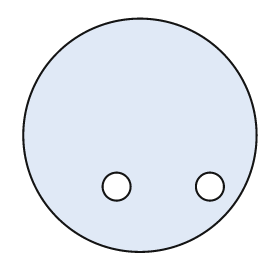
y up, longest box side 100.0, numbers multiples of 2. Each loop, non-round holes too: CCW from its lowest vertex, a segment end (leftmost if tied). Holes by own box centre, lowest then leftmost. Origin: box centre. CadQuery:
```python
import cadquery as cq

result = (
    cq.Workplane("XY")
    .moveTo(0.0, 0.0)
    .circle(50.0)
    .moveTo(-10.0, -22.0)
    .circle(6.0)
    .moveTo(30.0, -22.0)
    .circle(6.0)
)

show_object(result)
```